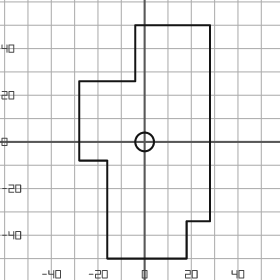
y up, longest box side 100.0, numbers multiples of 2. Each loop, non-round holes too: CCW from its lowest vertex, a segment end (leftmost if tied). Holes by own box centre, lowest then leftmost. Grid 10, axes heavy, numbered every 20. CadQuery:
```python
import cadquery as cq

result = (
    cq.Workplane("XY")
    .moveTo(-16.0, -50.0)
    .lineTo(18.0, -50.0)
    .lineTo(18.0, -34.0)
    .lineTo(28.0, -34.0)
    .lineTo(28.0, 50.0)
    .lineTo(-4.0, 50.0)
    .lineTo(-4.0, 26.0)
    .lineTo(-28.0, 26.0)
    .lineTo(-28.0, -8.0)
    .lineTo(-16.0, -8.0)
    .close()
    .moveTo(0.0, 0.0)
    .circle(4.0)
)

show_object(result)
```